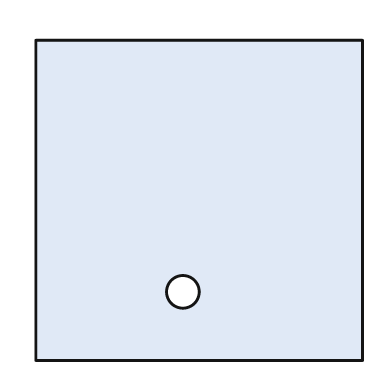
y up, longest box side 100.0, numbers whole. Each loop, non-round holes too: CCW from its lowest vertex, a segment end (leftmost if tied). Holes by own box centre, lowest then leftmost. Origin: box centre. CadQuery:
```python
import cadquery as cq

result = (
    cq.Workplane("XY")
    .moveTo(-50.0, -49.0)
    .lineTo(50.0, -49.0)
    .lineTo(50.0, 49.0)
    .lineTo(-50.0, 49.0)
    .close()
    .moveTo(-5.0, -28.0)
    .circle(5.0)
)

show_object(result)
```